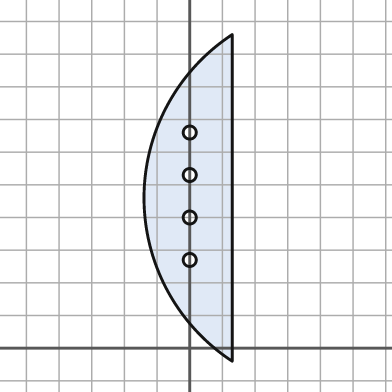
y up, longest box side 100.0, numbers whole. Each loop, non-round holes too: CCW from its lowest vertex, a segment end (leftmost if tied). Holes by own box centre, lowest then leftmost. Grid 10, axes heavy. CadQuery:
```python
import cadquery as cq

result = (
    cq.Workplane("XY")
    .moveTo(13.0, -4.0)
    .lineTo(13.0, 96.0)
    .threePointArc((-14.0, 46.0), (13.0, -4.0))
    .close()
    .moveTo(0.0, 27.0)
    .circle(2.0)
    .moveTo(0.0, 40.0)
    .circle(2.0)
    .moveTo(0.0, 53.0)
    .circle(2.0)
    .moveTo(0.0, 66.0)
    .circle(2.0)
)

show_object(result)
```